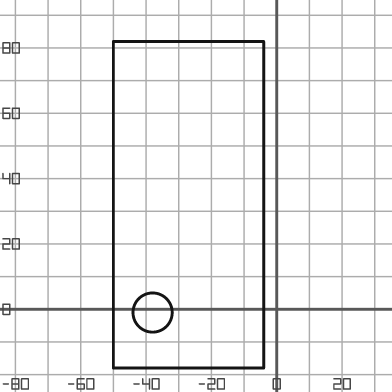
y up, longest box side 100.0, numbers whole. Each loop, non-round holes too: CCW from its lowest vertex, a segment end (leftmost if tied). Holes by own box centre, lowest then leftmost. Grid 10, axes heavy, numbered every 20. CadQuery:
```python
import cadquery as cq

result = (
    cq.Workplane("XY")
    .moveTo(-50.0, -18.0)
    .lineTo(-4.0, -18.0)
    .lineTo(-4.0, 82.0)
    .lineTo(-50.0, 82.0)
    .close()
    .moveTo(-38.0, -1.0)
    .circle(6.0)
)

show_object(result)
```